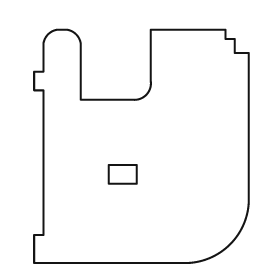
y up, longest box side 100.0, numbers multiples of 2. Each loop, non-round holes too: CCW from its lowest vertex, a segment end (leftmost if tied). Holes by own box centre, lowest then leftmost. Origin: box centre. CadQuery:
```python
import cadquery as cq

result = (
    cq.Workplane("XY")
    .moveTo(-46.0, -50.0)
    .lineTo(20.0, -50.0)
    .threePointArc((38.0, -42.0), (46.0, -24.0))
    .lineTo(46.0, 40.0)
    .lineTo(40.0, 40.0)
    .lineTo(40.0, 46.0)
    .lineTo(36.0, 46.0)
    .lineTo(36.0, 50.0)
    .lineTo(4.0, 50.0)
    .lineTo(4.0, 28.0)
    .threePointArc((2.0, 22.0), (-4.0, 20.0))
    .lineTo(-26.0, 20.0)
    .lineTo(-26.0, 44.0)
    .threePointArc((-28.0, 48.0), (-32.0, 50.0))
    .lineTo(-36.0, 50.0)
    .threePointArc((-40.0, 48.0), (-42.0, 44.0))
    .lineTo(-42.0, 32.0)
    .lineTo(-46.0, 32.0)
    .lineTo(-46.0, 24.0)
    .lineTo(-42.0, 24.0)
    .lineTo(-42.0, -38.0)
    .lineTo(-46.0, -38.0)
    .close()
    .moveTo(-14.0, -16.0)
    .lineTo(-2.0, -16.0)
    .lineTo(-2.0, -8.0)
    .lineTo(-14.0, -8.0)
    .close()
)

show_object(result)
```